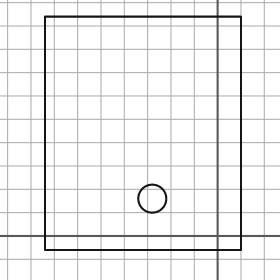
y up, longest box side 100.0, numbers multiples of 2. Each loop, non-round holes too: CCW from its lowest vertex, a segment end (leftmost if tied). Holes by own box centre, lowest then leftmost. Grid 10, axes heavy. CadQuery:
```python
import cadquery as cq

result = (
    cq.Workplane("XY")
    .moveTo(-74.0, -6.0)
    .lineTo(10.0, -6.0)
    .lineTo(10.0, 94.0)
    .lineTo(-74.0, 94.0)
    .close()
    .moveTo(-28.0, 16.0)
    .circle(6.0)
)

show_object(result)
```